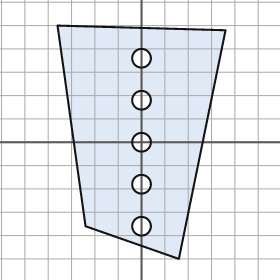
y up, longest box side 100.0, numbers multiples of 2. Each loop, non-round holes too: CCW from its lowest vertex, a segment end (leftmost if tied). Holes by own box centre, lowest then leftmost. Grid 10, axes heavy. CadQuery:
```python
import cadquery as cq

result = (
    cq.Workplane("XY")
    .moveTo(16.0, -50.0)
    .lineTo(36.0, 48.0)
    .lineTo(-36.0, 50.0)
    .lineTo(-24.0, -36.0)
    .close()
    .moveTo(0.0, -36.0)
    .circle(4.0)
    .moveTo(0.0, -18.0)
    .circle(4.0)
    .moveTo(0.0, 0.0)
    .circle(4.0)
    .moveTo(0.0, 18.0)
    .circle(4.0)
    .moveTo(0.0, 36.0)
    .circle(4.0)
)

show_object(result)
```